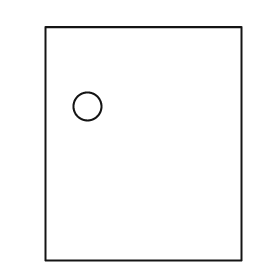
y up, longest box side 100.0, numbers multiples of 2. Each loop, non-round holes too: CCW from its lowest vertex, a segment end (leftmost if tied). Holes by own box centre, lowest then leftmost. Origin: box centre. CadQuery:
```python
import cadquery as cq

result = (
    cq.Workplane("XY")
    .moveTo(-42.0, -50.0)
    .lineTo(42.0, -50.0)
    .lineTo(42.0, 50.0)
    .lineTo(-42.0, 50.0)
    .close()
    .moveTo(-24.0, 16.0)
    .circle(6.0)
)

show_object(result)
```